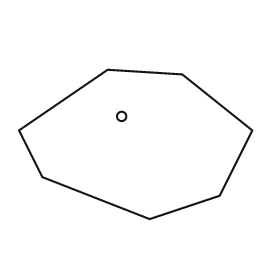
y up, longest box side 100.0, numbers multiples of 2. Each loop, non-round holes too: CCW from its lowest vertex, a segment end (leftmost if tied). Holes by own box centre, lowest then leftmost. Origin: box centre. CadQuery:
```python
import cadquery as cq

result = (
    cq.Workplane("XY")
    .moveTo(6.0, -32.0)
    .lineTo(36.0, -22.0)
    .lineTo(50.0, 6.0)
    .lineTo(20.0, 30.0)
    .lineTo(-12.0, 32.0)
    .lineTo(-50.0, 6.0)
    .lineTo(-40.0, -14.0)
    .close()
    .moveTo(-6.0, 12.0)
    .circle(2.0)
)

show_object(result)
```